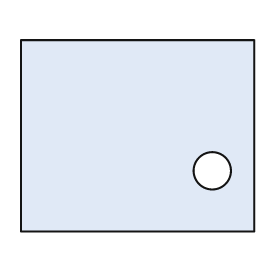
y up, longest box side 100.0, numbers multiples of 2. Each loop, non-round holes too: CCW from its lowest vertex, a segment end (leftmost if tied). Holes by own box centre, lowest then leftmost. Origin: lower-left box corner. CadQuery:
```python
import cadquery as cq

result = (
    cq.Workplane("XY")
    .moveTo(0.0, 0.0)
    .lineTo(100.0, 0.0)
    .lineTo(100.0, 82.0)
    .lineTo(0.0, 82.0)
    .close()
    .moveTo(82.0, 26.0)
    .circle(8.0)
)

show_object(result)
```